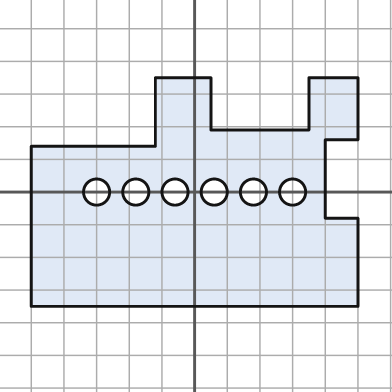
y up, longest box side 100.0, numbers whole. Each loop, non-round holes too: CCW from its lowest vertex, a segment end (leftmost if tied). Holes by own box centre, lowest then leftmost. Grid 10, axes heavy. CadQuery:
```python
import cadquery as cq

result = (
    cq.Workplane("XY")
    .moveTo(-50.0, -35.0)
    .lineTo(50.0, -35.0)
    .lineTo(50.0, -8.0)
    .lineTo(40.0, -8.0)
    .lineTo(40.0, 16.0)
    .lineTo(50.0, 16.0)
    .lineTo(50.0, 35.0)
    .lineTo(35.0, 35.0)
    .lineTo(35.0, 19.0)
    .lineTo(5.0, 19.0)
    .lineTo(5.0, 35.0)
    .lineTo(-12.0, 35.0)
    .lineTo(-12.0, 14.0)
    .lineTo(-50.0, 14.0)
    .close()
    .moveTo(-30.0, 0.0)
    .circle(4.0)
    .moveTo(-18.0, 0.0)
    .circle(4.0)
    .moveTo(-6.0, 0.0)
    .circle(4.0)
    .moveTo(6.0, 0.0)
    .circle(4.0)
    .moveTo(18.0, 0.0)
    .circle(4.0)
    .moveTo(30.0, 0.0)
    .circle(4.0)
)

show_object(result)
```